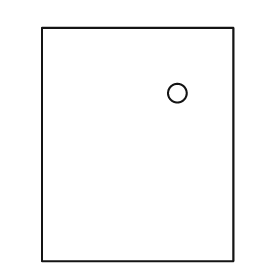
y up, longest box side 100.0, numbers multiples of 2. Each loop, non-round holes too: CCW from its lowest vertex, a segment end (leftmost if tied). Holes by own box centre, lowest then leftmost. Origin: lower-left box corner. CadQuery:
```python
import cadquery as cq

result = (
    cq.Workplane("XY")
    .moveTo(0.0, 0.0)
    .lineTo(82.0, 0.0)
    .lineTo(82.0, 100.0)
    .lineTo(0.0, 100.0)
    .close()
    .moveTo(58.0, 72.0)
    .circle(4.0)
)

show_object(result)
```